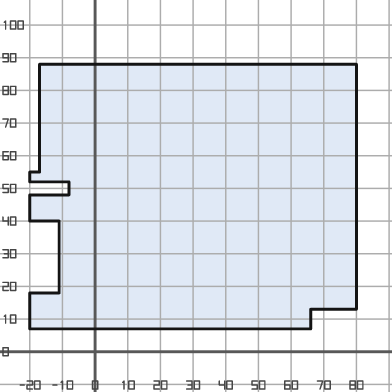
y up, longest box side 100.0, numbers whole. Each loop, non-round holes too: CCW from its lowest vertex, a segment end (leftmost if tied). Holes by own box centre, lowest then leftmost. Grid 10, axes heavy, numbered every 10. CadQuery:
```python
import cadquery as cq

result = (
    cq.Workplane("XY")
    .moveTo(-20.0, 7.0)
    .lineTo(66.0, 7.0)
    .lineTo(66.0, 13.0)
    .lineTo(80.0, 13.0)
    .lineTo(80.0, 88.0)
    .lineTo(-17.0, 88.0)
    .lineTo(-17.0, 55.0)
    .lineTo(-20.0, 55.0)
    .lineTo(-20.0, 52.0)
    .lineTo(-8.0, 52.0)
    .lineTo(-8.0, 48.0)
    .lineTo(-20.0, 48.0)
    .lineTo(-20.0, 40.0)
    .lineTo(-11.0, 40.0)
    .lineTo(-11.0, 18.0)
    .lineTo(-20.0, 18.0)
    .close()
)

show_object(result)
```